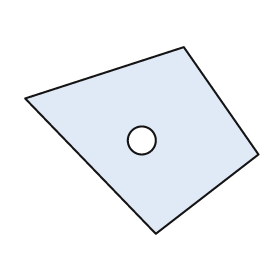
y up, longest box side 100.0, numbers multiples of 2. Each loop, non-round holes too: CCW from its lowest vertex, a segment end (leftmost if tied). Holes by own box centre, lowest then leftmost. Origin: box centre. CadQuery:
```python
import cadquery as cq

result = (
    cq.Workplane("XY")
    .moveTo(6.0, -40.0)
    .lineTo(50.0, -6.0)
    .lineTo(18.0, 40.0)
    .lineTo(-50.0, 18.0)
    .close()
    .moveTo(0.0, 0.0)
    .circle(6.0)
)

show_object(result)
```